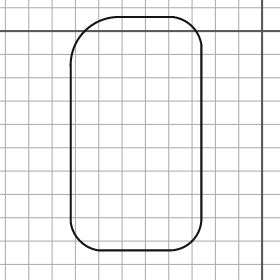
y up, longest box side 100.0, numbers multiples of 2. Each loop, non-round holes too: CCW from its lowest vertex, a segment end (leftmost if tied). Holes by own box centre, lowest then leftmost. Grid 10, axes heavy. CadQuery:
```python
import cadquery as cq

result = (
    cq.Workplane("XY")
    .moveTo(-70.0, -94.0)
    .lineTo(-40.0, -94.0)
    .threePointArc((-30.0, -90.0), (-26.0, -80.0))
    .lineTo(-26.0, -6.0)
    .threePointArc((-30.0, 2.0), (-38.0, 6.0))
    .lineTo(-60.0, 6.0)
    .threePointArc((-76.0, 0.0), (-82.0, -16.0))
    .lineTo(-82.0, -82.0)
    .threePointArc((-78.0, -90.0), (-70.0, -94.0))
    .close()
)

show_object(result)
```